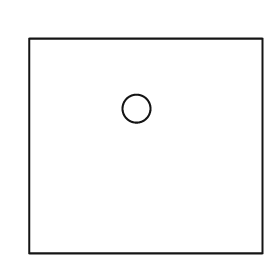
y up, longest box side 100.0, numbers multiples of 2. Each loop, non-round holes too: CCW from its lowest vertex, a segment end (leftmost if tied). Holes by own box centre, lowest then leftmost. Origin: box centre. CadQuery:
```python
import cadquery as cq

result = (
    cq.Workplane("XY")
    .moveTo(-50.0, -46.0)
    .lineTo(50.0, -46.0)
    .lineTo(50.0, 46.0)
    .lineTo(-50.0, 46.0)
    .close()
    .moveTo(-4.0, 16.0)
    .circle(6.0)
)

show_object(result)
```